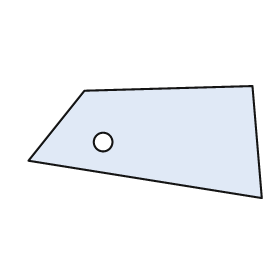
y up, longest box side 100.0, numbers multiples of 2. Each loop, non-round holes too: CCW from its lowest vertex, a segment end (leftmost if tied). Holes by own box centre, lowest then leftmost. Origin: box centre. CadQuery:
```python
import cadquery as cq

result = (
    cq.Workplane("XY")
    .moveTo(50.0, -24.0)
    .lineTo(46.0, 24.0)
    .lineTo(-26.0, 22.0)
    .lineTo(-50.0, -8.0)
    .close()
    .moveTo(-18.0, 0.0)
    .circle(4.0)
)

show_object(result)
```